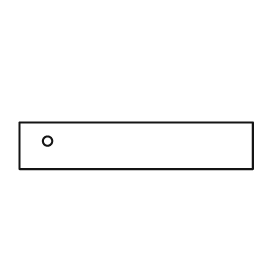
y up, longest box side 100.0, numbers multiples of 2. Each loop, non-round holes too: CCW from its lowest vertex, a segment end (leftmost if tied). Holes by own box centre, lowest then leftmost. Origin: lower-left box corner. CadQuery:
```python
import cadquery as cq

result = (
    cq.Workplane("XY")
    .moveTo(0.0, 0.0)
    .lineTo(100.0, 0.0)
    .lineTo(100.0, 20.0)
    .lineTo(0.0, 20.0)
    .close()
    .moveTo(12.0, 12.0)
    .circle(2.0)
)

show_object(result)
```